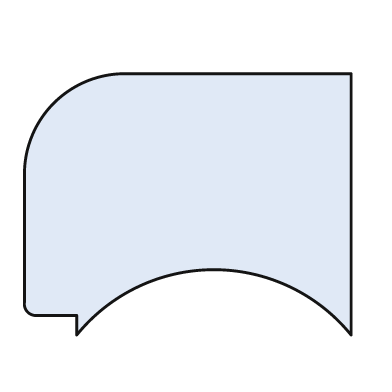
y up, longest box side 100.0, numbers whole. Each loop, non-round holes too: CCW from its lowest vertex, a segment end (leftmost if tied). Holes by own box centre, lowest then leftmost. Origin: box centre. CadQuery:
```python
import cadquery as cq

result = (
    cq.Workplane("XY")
    .moveTo(-34.0, -40.0)
    .threePointArc((8.0, -20.0), (50.0, -40.0))
    .lineTo(50.0, 40.0)
    .lineTo(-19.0, 40.0)
    .threePointArc((-41.0, 31.0), (-50.0, 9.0))
    .lineTo(-50.0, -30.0)
    .threePointArc((-49.0, -33.0), (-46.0, -34.0))
    .lineTo(-34.0, -34.0)
    .close()
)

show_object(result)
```